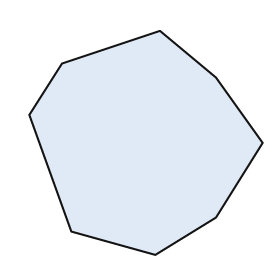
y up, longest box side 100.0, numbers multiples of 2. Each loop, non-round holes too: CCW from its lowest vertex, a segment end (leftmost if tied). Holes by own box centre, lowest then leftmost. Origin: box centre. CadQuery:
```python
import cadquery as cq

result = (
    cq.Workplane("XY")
    .moveTo(4.0, -48.0)
    .lineTo(30.0, -32.0)
    .lineTo(50.0, 0.0)
    .lineTo(30.0, 28.0)
    .lineTo(6.0, 48.0)
    .lineTo(-36.0, 34.0)
    .lineTo(-50.0, 12.0)
    .lineTo(-32.0, -38.0)
    .close()
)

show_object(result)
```